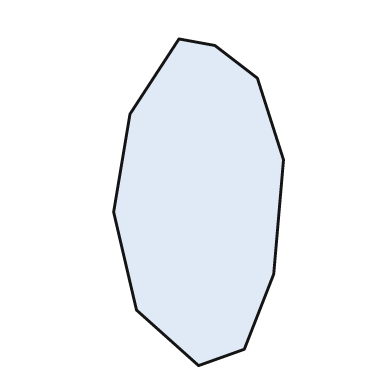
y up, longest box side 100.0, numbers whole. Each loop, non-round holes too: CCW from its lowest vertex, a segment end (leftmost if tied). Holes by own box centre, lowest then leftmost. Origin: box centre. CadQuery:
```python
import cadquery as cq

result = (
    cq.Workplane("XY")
    .moveTo(0.0, -50.0)
    .lineTo(14.0, -45.0)
    .lineTo(23.0, -22.0)
    .lineTo(26.0, 13.0)
    .lineTo(18.0, 38.0)
    .lineTo(5.0, 48.0)
    .lineTo(-6.0, 50.0)
    .lineTo(-21.0, 27.0)
    .lineTo(-26.0, -3.0)
    .lineTo(-19.0, -33.0)
    .close()
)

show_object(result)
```